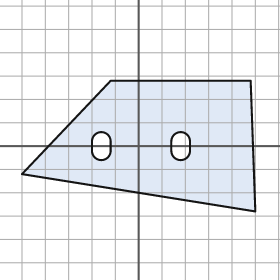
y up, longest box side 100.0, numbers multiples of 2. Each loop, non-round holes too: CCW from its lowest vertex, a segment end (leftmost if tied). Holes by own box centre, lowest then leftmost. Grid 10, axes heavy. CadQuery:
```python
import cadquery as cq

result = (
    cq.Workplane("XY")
    .moveTo(50.0, -28.0)
    .lineTo(48.0, 28.0)
    .lineTo(-12.0, 28.0)
    .lineTo(-50.0, -12.0)
    .close()
    .moveTo(-20.0, -2.0)
    .threePointArc((-16.0, -6.0), (-12.0, -2.0))
    .lineTo(-12.0, 2.0)
    .threePointArc((-16.0, 6.0), (-20.0, 2.0))
    .close()
    .moveTo(14.0, -2.0)
    .threePointArc((18.0, -6.0), (22.0, -2.0))
    .lineTo(22.0, 2.0)
    .threePointArc((18.0, 6.0), (14.0, 2.0))
    .close()
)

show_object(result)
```